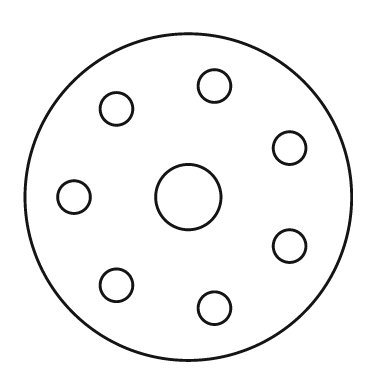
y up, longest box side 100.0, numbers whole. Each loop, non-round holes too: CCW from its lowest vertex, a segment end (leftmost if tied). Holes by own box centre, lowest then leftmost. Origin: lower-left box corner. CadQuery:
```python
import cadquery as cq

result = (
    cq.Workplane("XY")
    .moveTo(50.0, 50.0)
    .circle(50.0)
    .moveTo(58.0, 16.0)
    .circle(5.0)
    .moveTo(28.0, 23.0)
    .circle(5.0)
    .moveTo(81.0, 35.0)
    .circle(5.0)
    .moveTo(15.0, 50.0)
    .circle(5.0)
    .moveTo(50.0, 50.0)
    .circle(10.0)
    .moveTo(81.0, 65.0)
    .circle(5.0)
    .moveTo(28.0, 77.0)
    .circle(5.0)
    .moveTo(58.0, 84.0)
    .circle(5.0)
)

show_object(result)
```